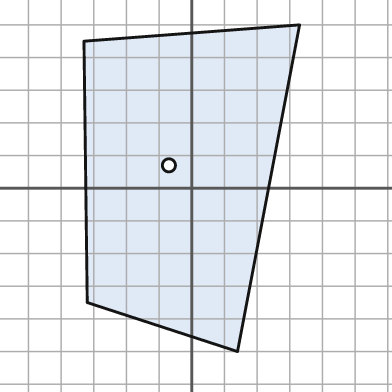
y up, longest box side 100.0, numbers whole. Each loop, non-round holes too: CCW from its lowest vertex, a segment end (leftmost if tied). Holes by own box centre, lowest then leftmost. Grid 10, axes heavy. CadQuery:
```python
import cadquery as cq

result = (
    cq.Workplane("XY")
    .moveTo(14.0, -50.0)
    .lineTo(33.0, 50.0)
    .lineTo(-33.0, 45.0)
    .lineTo(-32.0, -35.0)
    .close()
    .moveTo(-7.0, 7.0)
    .circle(2.0)
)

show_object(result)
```